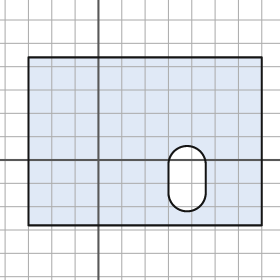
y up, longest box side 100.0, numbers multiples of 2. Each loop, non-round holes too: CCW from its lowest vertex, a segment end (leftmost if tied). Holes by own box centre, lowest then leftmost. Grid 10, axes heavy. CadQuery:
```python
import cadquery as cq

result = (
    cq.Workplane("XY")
    .moveTo(-30.0, -28.0)
    .lineTo(70.0, -28.0)
    .lineTo(70.0, 44.0)
    .lineTo(-30.0, 44.0)
    .close()
    .moveTo(30.0, -14.0)
    .threePointArc((38.0, -22.0), (46.0, -14.0))
    .lineTo(46.0, -2.0)
    .threePointArc((38.0, 6.0), (30.0, -2.0))
    .close()
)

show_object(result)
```